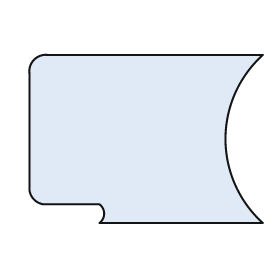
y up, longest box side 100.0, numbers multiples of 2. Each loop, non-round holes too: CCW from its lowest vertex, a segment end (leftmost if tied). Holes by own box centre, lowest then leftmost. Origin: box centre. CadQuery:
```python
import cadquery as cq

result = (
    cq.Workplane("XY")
    .moveTo(-20.0, -36.0)
    .lineTo(50.0, -36.0)
    .threePointArc((34.0, 0.0), (50.0, 36.0))
    .lineTo(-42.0, 36.0)
    .threePointArc((-48.0, 34.0), (-50.0, 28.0))
    .lineTo(-50.0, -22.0)
    .threePointArc((-48.0, -26.0), (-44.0, -28.0))
    .lineTo(-20.0, -28.0)
    .threePointArc((-18.0, -32.0), (-20.0, -36.0))
    .close()
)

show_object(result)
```